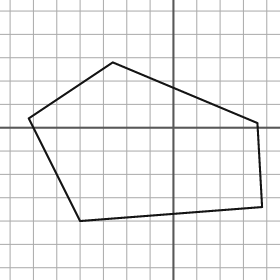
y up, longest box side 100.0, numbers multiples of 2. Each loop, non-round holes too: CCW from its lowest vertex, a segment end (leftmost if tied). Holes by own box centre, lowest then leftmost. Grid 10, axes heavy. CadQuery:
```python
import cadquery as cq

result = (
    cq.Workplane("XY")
    .moveTo(-40.0, -40.0)
    .lineTo(38.0, -34.0)
    .lineTo(36.0, 2.0)
    .lineTo(-26.0, 28.0)
    .lineTo(-62.0, 4.0)
    .close()
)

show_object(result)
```